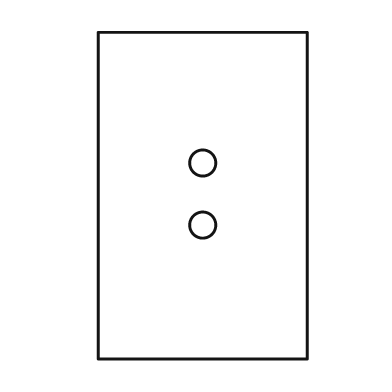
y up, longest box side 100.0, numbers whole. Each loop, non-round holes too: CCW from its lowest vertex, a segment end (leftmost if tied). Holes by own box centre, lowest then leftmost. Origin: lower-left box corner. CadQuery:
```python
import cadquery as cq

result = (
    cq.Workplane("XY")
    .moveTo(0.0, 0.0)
    .lineTo(64.0, 0.0)
    .lineTo(64.0, 100.0)
    .lineTo(0.0, 100.0)
    .close()
    .moveTo(32.0, 41.0)
    .circle(4.0)
    .moveTo(32.0, 60.0)
    .circle(4.0)
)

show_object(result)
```